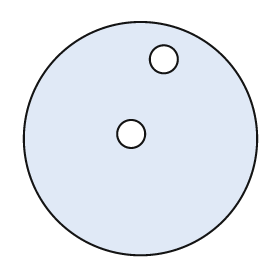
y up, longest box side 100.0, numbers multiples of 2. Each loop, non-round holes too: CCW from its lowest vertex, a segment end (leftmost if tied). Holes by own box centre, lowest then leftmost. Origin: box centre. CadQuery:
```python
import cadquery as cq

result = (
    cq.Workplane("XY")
    .moveTo(0.0, 0.0)
    .circle(50.0)
    .moveTo(-4.0, 2.0)
    .circle(6.0)
    .moveTo(10.0, 34.0)
    .circle(6.0)
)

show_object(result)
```